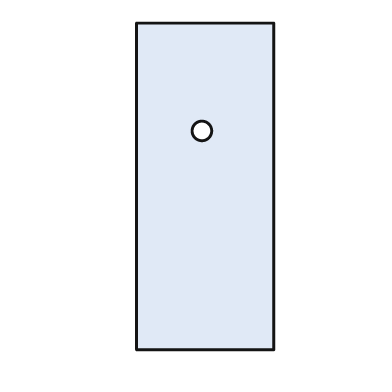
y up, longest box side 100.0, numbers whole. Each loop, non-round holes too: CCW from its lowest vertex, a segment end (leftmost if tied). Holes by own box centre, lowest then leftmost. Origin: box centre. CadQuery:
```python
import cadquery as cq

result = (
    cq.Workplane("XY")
    .moveTo(-21.0, -50.0)
    .lineTo(21.0, -50.0)
    .lineTo(21.0, 50.0)
    .lineTo(-21.0, 50.0)
    .close()
    .moveTo(-1.0, 17.0)
    .circle(3.0)
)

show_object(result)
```